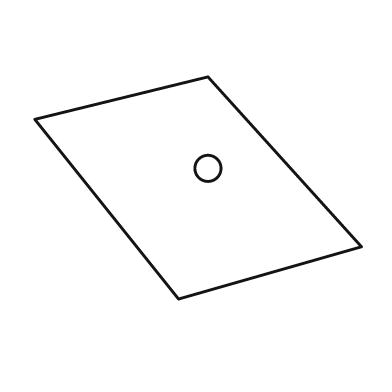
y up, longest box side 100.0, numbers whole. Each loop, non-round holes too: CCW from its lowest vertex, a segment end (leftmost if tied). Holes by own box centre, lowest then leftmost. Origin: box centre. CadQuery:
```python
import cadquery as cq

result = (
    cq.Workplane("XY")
    .moveTo(-6.0, -34.0)
    .lineTo(50.0, -18.0)
    .lineTo(3.0, 34.0)
    .lineTo(-50.0, 21.0)
    .close()
    .moveTo(3.0, 6.0)
    .circle(4.0)
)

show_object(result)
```